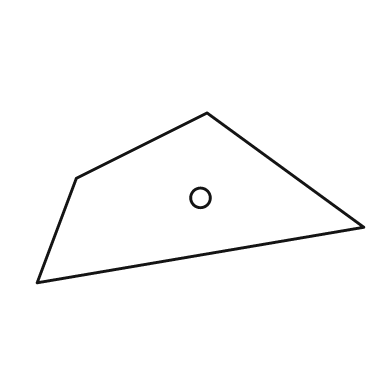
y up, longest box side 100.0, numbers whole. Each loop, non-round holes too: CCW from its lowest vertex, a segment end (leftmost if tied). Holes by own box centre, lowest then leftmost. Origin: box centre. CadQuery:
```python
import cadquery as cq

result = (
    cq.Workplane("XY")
    .moveTo(-50.0, -26.0)
    .lineTo(50.0, -9.0)
    .lineTo(2.0, 26.0)
    .lineTo(-38.0, 6.0)
    .close()
    .moveTo(0.0, 0.0)
    .circle(3.0)
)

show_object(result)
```